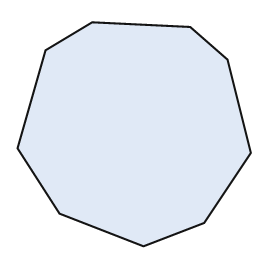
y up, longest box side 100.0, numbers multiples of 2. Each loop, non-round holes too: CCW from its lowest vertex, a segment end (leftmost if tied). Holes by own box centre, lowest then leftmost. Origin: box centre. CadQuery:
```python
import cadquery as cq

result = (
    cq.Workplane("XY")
    .moveTo(4.0, -48.0)
    .lineTo(30.0, -38.0)
    .lineTo(50.0, -8.0)
    .lineTo(40.0, 32.0)
    .lineTo(24.0, 46.0)
    .lineTo(-18.0, 48.0)
    .lineTo(-38.0, 36.0)
    .lineTo(-50.0, -6.0)
    .lineTo(-32.0, -34.0)
    .close()
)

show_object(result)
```